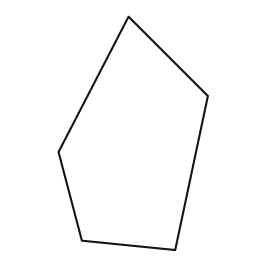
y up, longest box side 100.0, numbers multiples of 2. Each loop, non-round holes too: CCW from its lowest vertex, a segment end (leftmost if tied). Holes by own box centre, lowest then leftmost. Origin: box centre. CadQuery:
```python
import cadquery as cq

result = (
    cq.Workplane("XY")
    .moveTo(18.0, -50.0)
    .lineTo(32.0, 16.0)
    .lineTo(-2.0, 50.0)
    .lineTo(-32.0, -8.0)
    .lineTo(-22.0, -46.0)
    .close()
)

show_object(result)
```